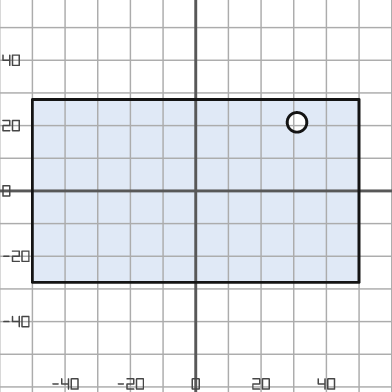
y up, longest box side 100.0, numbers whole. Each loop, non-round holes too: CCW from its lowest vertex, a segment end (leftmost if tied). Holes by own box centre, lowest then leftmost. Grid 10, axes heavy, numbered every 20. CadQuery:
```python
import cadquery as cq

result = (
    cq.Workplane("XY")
    .moveTo(-50.0, -28.0)
    .lineTo(50.0, -28.0)
    .lineTo(50.0, 28.0)
    .lineTo(-50.0, 28.0)
    .close()
    .moveTo(31.0, 21.0)
    .circle(3.0)
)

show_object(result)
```